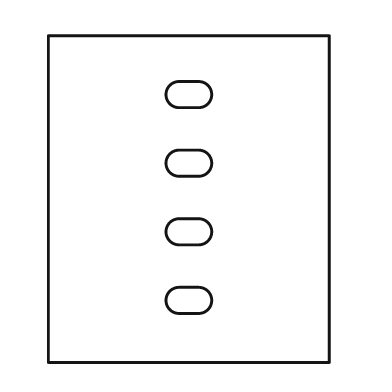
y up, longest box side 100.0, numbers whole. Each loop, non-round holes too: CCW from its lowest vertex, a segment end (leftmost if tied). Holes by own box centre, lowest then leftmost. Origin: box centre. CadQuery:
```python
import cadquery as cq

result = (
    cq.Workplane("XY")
    .moveTo(-43.0, -50.0)
    .lineTo(43.0, -50.0)
    .lineTo(43.0, 50.0)
    .lineTo(-43.0, 50.0)
    .close()
    .moveTo(-3.0, -35.0)
    .lineTo(3.0, -35.0)
    .threePointArc((7.0, -31.0), (3.0, -27.0))
    .lineTo(-3.0, -27.0)
    .threePointArc((-7.0, -31.0), (-3.0, -35.0))
    .close()
    .moveTo(-3.0, -14.0)
    .lineTo(3.0, -14.0)
    .threePointArc((7.0, -10.0), (3.0, -6.0))
    .lineTo(-3.0, -6.0)
    .threePointArc((-7.0, -10.0), (-3.0, -14.0))
    .close()
    .moveTo(-3.0, 7.0)
    .lineTo(3.0, 7.0)
    .threePointArc((7.0, 11.0), (3.0, 15.0))
    .lineTo(-3.0, 15.0)
    .threePointArc((-7.0, 11.0), (-3.0, 7.0))
    .close()
    .moveTo(-3.0, 28.0)
    .lineTo(3.0, 28.0)
    .threePointArc((7.0, 32.0), (3.0, 36.0))
    .lineTo(-3.0, 36.0)
    .threePointArc((-7.0, 32.0), (-3.0, 28.0))
    .close()
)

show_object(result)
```